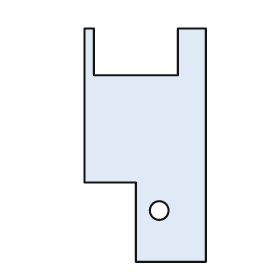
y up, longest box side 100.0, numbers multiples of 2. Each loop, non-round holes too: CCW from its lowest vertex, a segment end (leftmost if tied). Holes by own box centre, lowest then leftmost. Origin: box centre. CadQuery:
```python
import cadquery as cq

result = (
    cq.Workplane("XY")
    .moveTo(-4.0, -50.0)
    .lineTo(26.0, -50.0)
    .lineTo(26.0, 50.0)
    .lineTo(14.0, 50.0)
    .lineTo(14.0, 30.0)
    .lineTo(-22.0, 30.0)
    .lineTo(-22.0, 50.0)
    .lineTo(-26.0, 50.0)
    .lineTo(-26.0, -16.0)
    .lineTo(-4.0, -16.0)
    .close()
    .moveTo(6.0, -28.0)
    .circle(4.0)
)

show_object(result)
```